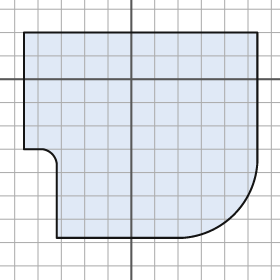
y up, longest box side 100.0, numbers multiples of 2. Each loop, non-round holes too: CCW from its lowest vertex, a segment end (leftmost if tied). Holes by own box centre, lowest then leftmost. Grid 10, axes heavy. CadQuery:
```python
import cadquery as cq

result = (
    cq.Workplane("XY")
    .moveTo(-32.0, -68.0)
    .lineTo(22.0, -68.0)
    .threePointArc((44.0, -58.0), (54.0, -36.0))
    .lineTo(54.0, 20.0)
    .lineTo(-46.0, 20.0)
    .lineTo(-46.0, -30.0)
    .lineTo(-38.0, -30.0)
    .threePointArc((-34.0, -32.0), (-32.0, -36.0))
    .close()
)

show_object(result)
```